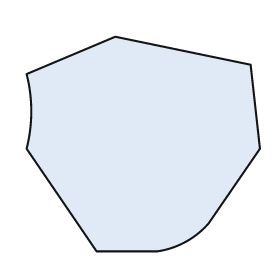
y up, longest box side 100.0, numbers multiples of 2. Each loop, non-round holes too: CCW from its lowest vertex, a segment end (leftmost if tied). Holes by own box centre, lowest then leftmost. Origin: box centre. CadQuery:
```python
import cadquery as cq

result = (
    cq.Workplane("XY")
    .moveTo(-20.0, -46.0)
    .lineTo(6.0, -46.0)
    .threePointArc((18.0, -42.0), (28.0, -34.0))
    .lineTo(50.0, -2.0)
    .lineTo(46.0, 34.0)
    .lineTo(-12.0, 46.0)
    .lineTo(-50.0, 30.0)
    .threePointArc((-48.0, 14.0), (-50.0, -2.0))
    .close()
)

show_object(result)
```